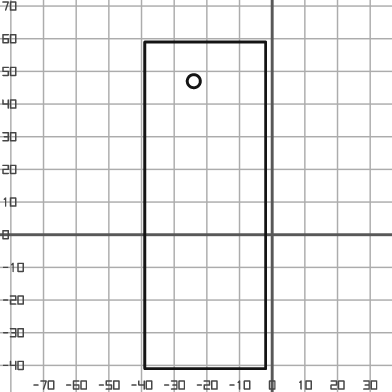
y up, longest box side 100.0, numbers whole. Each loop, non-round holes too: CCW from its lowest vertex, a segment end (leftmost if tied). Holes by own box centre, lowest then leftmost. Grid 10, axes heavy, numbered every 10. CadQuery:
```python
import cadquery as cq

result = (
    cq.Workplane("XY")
    .moveTo(-39.0, -41.0)
    .lineTo(-2.0, -41.0)
    .lineTo(-2.0, 59.0)
    .lineTo(-39.0, 59.0)
    .close()
    .moveTo(-24.0, 47.0)
    .circle(2.0)
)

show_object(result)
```